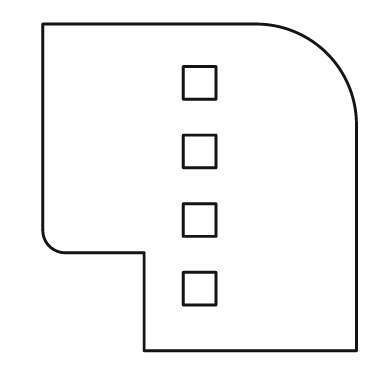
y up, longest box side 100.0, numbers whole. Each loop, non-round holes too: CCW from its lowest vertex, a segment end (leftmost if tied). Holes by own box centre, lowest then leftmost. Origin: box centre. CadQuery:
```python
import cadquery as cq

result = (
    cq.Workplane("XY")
    .moveTo(-17.0, -50.0)
    .lineTo(48.0, -50.0)
    .lineTo(48.0, 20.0)
    .threePointArc((39.0, 41.0), (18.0, 50.0))
    .lineTo(-48.0, 50.0)
    .lineTo(-48.0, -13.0)
    .threePointArc((-46.0, -18.0), (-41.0, -20.0))
    .lineTo(-17.0, -20.0)
    .close()
    .moveTo(-5.0, -36.0)
    .lineTo(5.0, -36.0)
    .lineTo(5.0, -26.0)
    .lineTo(-5.0, -26.0)
    .close()
    .moveTo(-5.0, -15.0)
    .lineTo(5.0, -15.0)
    .lineTo(5.0, -5.0)
    .lineTo(-5.0, -5.0)
    .close()
    .moveTo(-5.0, 6.0)
    .lineTo(5.0, 6.0)
    .lineTo(5.0, 16.0)
    .lineTo(-5.0, 16.0)
    .close()
    .moveTo(-5.0, 27.0)
    .lineTo(5.0, 27.0)
    .lineTo(5.0, 37.0)
    .lineTo(-5.0, 37.0)
    .close()
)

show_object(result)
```